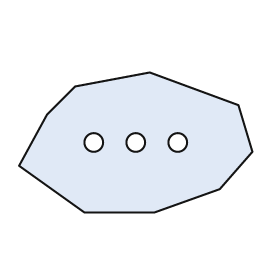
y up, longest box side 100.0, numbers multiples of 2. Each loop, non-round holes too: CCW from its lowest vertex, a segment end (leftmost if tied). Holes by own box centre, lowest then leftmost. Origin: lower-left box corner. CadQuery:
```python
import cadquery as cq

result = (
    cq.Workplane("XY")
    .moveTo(28.0, 0.0)
    .lineTo(58.0, 0.0)
    .lineTo(86.0, 10.0)
    .lineTo(100.0, 26.0)
    .lineTo(94.0, 46.0)
    .lineTo(56.0, 60.0)
    .lineTo(24.0, 54.0)
    .lineTo(12.0, 42.0)
    .lineTo(0.0, 20.0)
    .close()
    .moveTo(32.0, 30.0)
    .circle(4.0)
    .moveTo(50.0, 30.0)
    .circle(4.0)
    .moveTo(68.0, 30.0)
    .circle(4.0)
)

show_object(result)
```